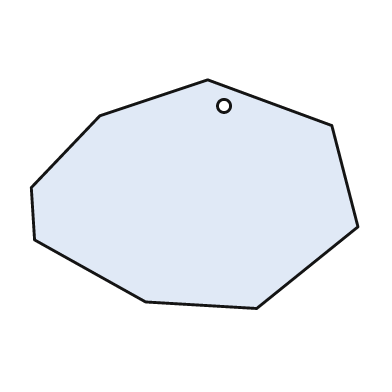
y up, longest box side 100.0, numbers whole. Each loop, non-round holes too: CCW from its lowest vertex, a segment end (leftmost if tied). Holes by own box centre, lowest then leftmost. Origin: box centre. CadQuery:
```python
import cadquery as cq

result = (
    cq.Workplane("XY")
    .moveTo(19.0, -35.0)
    .lineTo(50.0, -10.0)
    .lineTo(42.0, 21.0)
    .lineTo(4.0, 35.0)
    .lineTo(-29.0, 24.0)
    .lineTo(-50.0, 2.0)
    .lineTo(-49.0, -14.0)
    .lineTo(-15.0, -33.0)
    .close()
    .moveTo(9.0, 27.0)
    .circle(2.0)
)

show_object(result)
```